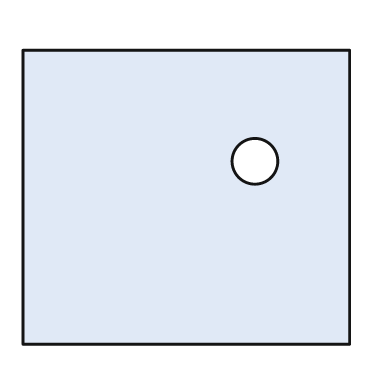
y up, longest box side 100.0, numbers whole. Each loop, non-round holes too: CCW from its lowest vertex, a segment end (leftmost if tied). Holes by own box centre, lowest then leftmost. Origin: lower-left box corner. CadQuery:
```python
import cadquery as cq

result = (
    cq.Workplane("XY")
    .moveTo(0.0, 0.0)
    .lineTo(100.0, 0.0)
    .lineTo(100.0, 90.0)
    .lineTo(0.0, 90.0)
    .close()
    .moveTo(71.0, 56.0)
    .circle(7.0)
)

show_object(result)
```